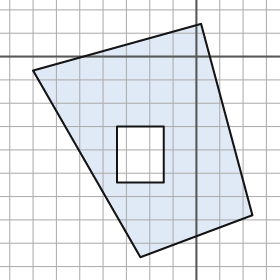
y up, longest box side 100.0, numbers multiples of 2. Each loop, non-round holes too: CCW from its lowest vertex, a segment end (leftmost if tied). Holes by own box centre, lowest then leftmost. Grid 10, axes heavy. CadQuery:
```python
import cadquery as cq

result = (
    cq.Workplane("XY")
    .moveTo(-24.0, -86.0)
    .lineTo(24.0, -68.0)
    .lineTo(2.0, 14.0)
    .lineTo(-70.0, -6.0)
    .close()
    .moveTo(-34.0, -54.0)
    .lineTo(-14.0, -54.0)
    .lineTo(-14.0, -30.0)
    .lineTo(-34.0, -30.0)
    .close()
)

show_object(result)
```